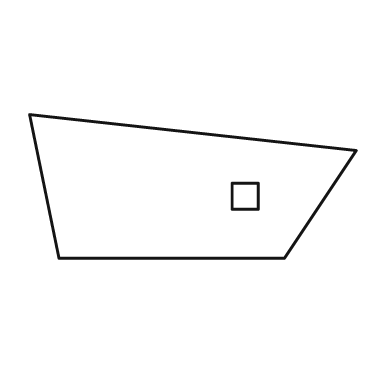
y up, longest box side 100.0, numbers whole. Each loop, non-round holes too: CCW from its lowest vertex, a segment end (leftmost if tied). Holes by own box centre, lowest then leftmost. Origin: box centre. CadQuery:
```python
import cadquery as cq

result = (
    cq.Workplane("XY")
    .moveTo(-41.0, -22.0)
    .lineTo(28.0, -22.0)
    .lineTo(50.0, 11.0)
    .lineTo(-50.0, 22.0)
    .close()
    .moveTo(12.0, -7.0)
    .lineTo(20.0, -7.0)
    .lineTo(20.0, 1.0)
    .lineTo(12.0, 1.0)
    .close()
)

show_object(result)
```